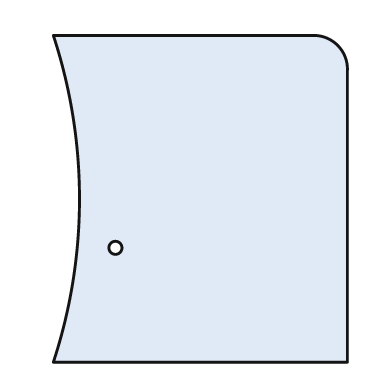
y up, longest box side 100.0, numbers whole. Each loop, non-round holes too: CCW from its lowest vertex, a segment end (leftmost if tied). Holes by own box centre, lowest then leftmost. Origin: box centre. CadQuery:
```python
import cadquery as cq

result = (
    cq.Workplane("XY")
    .moveTo(-45.0, -50.0)
    .lineTo(45.0, -50.0)
    .lineTo(45.0, 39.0)
    .threePointArc((42.0, 47.0), (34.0, 50.0))
    .lineTo(-45.0, 50.0)
    .threePointArc((-37.0, 0.0), (-45.0, -50.0))
    .close()
    .moveTo(-26.0, -15.0)
    .circle(2.0)
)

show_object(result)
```